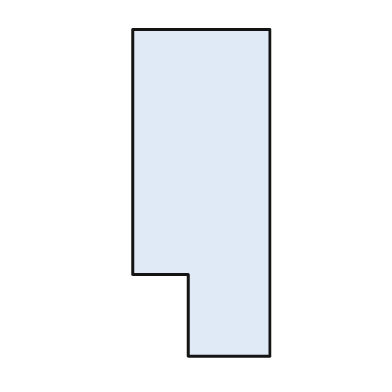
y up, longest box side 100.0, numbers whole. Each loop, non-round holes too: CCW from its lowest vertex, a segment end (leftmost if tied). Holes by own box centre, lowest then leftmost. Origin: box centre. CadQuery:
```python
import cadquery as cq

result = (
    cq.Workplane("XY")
    .moveTo(-4.0, -50.0)
    .lineTo(21.0, -50.0)
    .lineTo(21.0, 50.0)
    .lineTo(-21.0, 50.0)
    .lineTo(-21.0, -25.0)
    .lineTo(-4.0, -25.0)
    .close()
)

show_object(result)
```